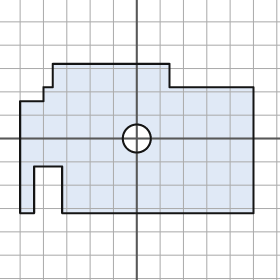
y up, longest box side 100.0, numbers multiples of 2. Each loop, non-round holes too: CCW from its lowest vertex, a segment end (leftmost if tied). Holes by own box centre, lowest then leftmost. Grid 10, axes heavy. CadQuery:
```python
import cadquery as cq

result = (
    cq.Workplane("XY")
    .moveTo(-50.0, -32.0)
    .lineTo(-44.0, -32.0)
    .lineTo(-44.0, -12.0)
    .lineTo(-32.0, -12.0)
    .lineTo(-32.0, -32.0)
    .lineTo(50.0, -32.0)
    .lineTo(50.0, 22.0)
    .lineTo(14.0, 22.0)
    .lineTo(14.0, 32.0)
    .lineTo(-36.0, 32.0)
    .lineTo(-36.0, 22.0)
    .lineTo(-40.0, 22.0)
    .lineTo(-40.0, 16.0)
    .lineTo(-50.0, 16.0)
    .close()
    .moveTo(0.0, 0.0)
    .circle(6.0)
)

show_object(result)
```